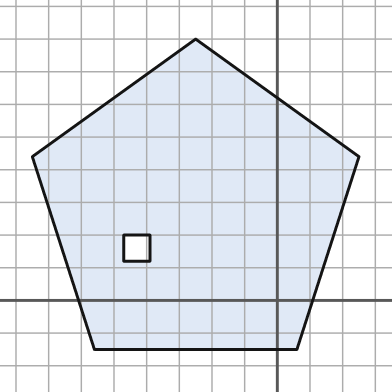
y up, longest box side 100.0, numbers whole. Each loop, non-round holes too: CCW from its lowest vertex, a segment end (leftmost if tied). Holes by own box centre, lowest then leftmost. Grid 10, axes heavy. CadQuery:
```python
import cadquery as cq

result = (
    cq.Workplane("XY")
    .moveTo(-56.0, -15.0)
    .lineTo(6.0, -15.0)
    .lineTo(25.0, 44.0)
    .lineTo(-25.0, 80.0)
    .lineTo(-75.0, 44.0)
    .close()
    .moveTo(-47.0, 12.0)
    .lineTo(-39.0, 12.0)
    .lineTo(-39.0, 20.0)
    .lineTo(-47.0, 20.0)
    .close()
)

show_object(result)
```